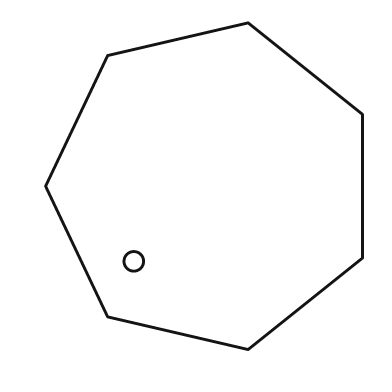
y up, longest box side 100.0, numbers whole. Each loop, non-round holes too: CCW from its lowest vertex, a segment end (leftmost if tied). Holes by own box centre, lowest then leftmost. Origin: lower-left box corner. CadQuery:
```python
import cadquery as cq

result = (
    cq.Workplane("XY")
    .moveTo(62.0, 0.0)
    .lineTo(97.0, 28.0)
    .lineTo(97.0, 72.0)
    .lineTo(62.0, 100.0)
    .lineTo(19.0, 90.0)
    .lineTo(0.0, 50.0)
    .lineTo(19.0, 10.0)
    .close()
    .moveTo(27.0, 27.0)
    .circle(3.0)
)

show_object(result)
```